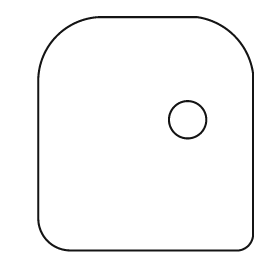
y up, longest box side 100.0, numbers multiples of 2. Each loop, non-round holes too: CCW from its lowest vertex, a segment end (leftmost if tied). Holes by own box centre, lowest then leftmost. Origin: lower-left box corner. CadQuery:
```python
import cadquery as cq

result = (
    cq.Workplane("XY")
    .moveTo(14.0, 0.0)
    .lineTo(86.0, 0.0)
    .threePointArc((90.0, 2.0), (92.0, 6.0))
    .lineTo(92.0, 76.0)
    .threePointArc((84.0, 92.0), (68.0, 100.0))
    .lineTo(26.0, 100.0)
    .threePointArc((8.0, 92.0), (0.0, 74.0))
    .lineTo(0.0, 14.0)
    .threePointArc((4.0, 4.0), (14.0, 0.0))
    .close()
    .moveTo(64.0, 56.0)
    .circle(8.0)
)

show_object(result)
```